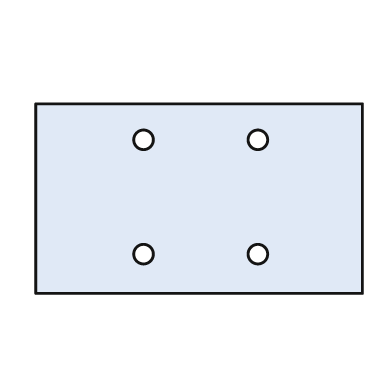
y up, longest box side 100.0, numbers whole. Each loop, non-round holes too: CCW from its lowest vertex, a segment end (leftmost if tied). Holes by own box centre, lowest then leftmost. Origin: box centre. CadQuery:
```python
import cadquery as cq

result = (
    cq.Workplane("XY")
    .moveTo(-50.0, -29.0)
    .lineTo(50.0, -29.0)
    .lineTo(50.0, 29.0)
    .lineTo(-50.0, 29.0)
    .close()
    .moveTo(-17.0, -17.0)
    .circle(3.0)
    .moveTo(18.0, -17.0)
    .circle(3.0)
    .moveTo(-17.0, 18.0)
    .circle(3.0)
    .moveTo(18.0, 18.0)
    .circle(3.0)
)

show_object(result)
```